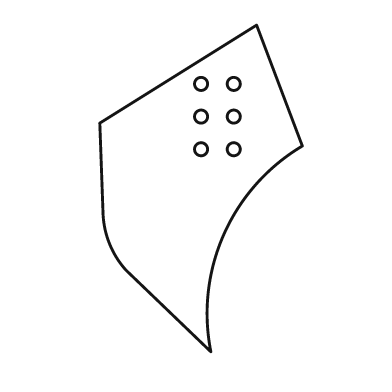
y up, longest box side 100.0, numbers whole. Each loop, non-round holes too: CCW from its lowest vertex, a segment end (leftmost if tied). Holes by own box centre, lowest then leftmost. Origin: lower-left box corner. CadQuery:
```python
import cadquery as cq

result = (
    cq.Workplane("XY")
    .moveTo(34.0, 0.0)
    .threePointArc((38.0, 36.0), (62.0, 63.0))
    .lineTo(48.0, 100.0)
    .lineTo(0.0, 70.0)
    .lineTo(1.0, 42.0)
    .threePointArc((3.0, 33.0), (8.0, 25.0))
    .close()
    .moveTo(31.0, 62.0)
    .circle(2.0)
    .moveTo(41.0, 62.0)
    .circle(2.0)
    .moveTo(31.0, 72.0)
    .circle(2.0)
    .moveTo(41.0, 72.0)
    .circle(2.0)
    .moveTo(31.0, 82.0)
    .circle(2.0)
    .moveTo(41.0, 82.0)
    .circle(2.0)
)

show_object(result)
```